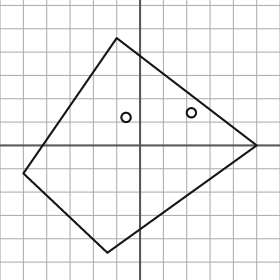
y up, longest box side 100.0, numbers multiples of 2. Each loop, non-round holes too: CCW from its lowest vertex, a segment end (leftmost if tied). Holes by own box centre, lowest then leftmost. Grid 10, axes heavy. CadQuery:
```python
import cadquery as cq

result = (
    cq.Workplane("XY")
    .moveTo(-14.0, -46.0)
    .lineTo(50.0, 0.0)
    .lineTo(-10.0, 46.0)
    .lineTo(-50.0, -12.0)
    .close()
    .moveTo(-6.0, 12.0)
    .circle(2.0)
    .moveTo(22.0, 14.0)
    .circle(2.0)
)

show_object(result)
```